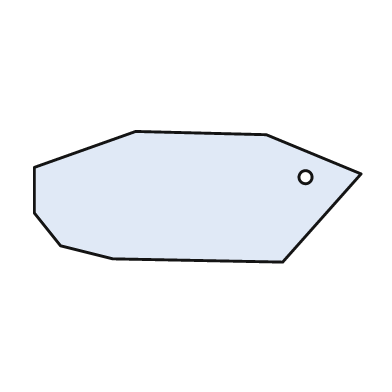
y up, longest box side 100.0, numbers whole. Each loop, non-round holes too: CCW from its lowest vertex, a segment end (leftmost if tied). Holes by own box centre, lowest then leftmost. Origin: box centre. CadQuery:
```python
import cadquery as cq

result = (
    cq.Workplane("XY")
    .moveTo(26.0, -20.0)
    .lineTo(50.0, 7.0)
    .lineTo(21.0, 19.0)
    .lineTo(-19.0, 20.0)
    .lineTo(-50.0, 9.0)
    .lineTo(-50.0, -5.0)
    .lineTo(-42.0, -15.0)
    .lineTo(-26.0, -19.0)
    .close()
    .moveTo(33.0, 6.0)
    .circle(2.0)
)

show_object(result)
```